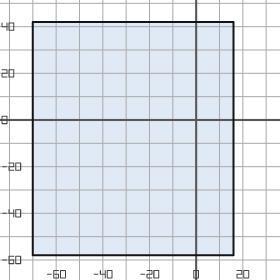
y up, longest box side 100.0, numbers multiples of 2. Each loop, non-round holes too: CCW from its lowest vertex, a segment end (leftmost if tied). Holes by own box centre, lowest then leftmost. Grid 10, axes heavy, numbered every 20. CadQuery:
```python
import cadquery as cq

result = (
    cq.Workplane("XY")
    .moveTo(-70.0, -58.0)
    .lineTo(16.0, -58.0)
    .lineTo(16.0, 42.0)
    .lineTo(-70.0, 42.0)
    .close()
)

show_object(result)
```